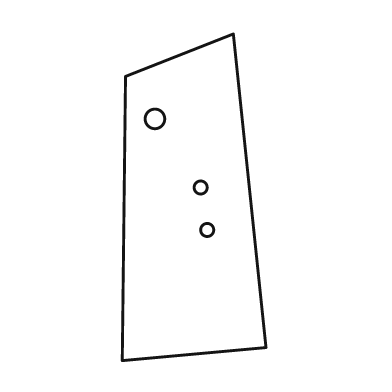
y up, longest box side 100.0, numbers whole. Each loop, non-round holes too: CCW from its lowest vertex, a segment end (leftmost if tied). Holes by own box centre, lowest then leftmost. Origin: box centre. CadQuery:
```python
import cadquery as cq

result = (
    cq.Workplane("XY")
    .moveTo(-22.0, -50.0)
    .lineTo(22.0, -46.0)
    .lineTo(12.0, 50.0)
    .lineTo(-21.0, 37.0)
    .close()
    .moveTo(4.0, -10.0)
    .circle(2.0)
    .moveTo(2.0, 3.0)
    .circle(2.0)
    .moveTo(-12.0, 24.0)
    .circle(3.0)
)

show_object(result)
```